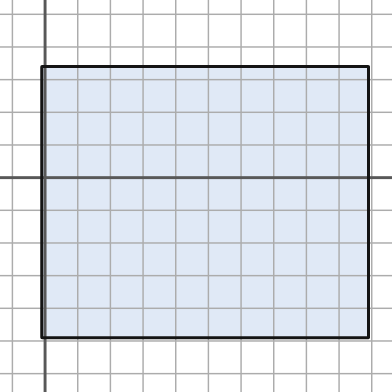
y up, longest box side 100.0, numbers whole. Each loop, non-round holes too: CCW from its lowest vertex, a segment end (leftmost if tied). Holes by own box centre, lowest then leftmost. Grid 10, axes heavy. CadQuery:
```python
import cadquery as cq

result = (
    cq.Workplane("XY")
    .moveTo(-1.0, -49.0)
    .lineTo(99.0, -49.0)
    .lineTo(99.0, 34.0)
    .lineTo(-1.0, 34.0)
    .close()
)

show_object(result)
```